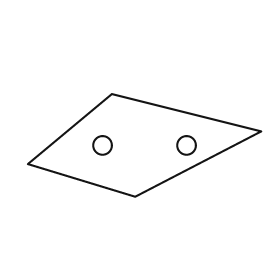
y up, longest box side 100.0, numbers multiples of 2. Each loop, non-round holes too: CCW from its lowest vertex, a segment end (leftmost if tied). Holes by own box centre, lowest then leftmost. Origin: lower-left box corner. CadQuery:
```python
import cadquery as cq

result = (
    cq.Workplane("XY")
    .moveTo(46.0, 0.0)
    .lineTo(100.0, 28.0)
    .lineTo(36.0, 44.0)
    .lineTo(0.0, 14.0)
    .close()
    .moveTo(32.0, 22.0)
    .circle(4.0)
    .moveTo(68.0, 22.0)
    .circle(4.0)
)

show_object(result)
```